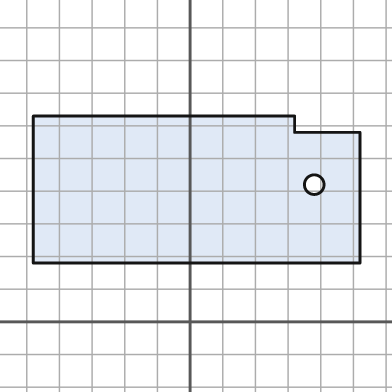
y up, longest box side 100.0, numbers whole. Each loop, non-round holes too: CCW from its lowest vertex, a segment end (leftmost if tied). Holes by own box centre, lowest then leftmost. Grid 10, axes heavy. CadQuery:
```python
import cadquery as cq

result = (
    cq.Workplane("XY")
    .moveTo(-48.0, 18.0)
    .lineTo(52.0, 18.0)
    .lineTo(52.0, 58.0)
    .lineTo(32.0, 58.0)
    .lineTo(32.0, 63.0)
    .lineTo(-48.0, 63.0)
    .close()
    .moveTo(38.0, 42.0)
    .circle(3.0)
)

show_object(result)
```